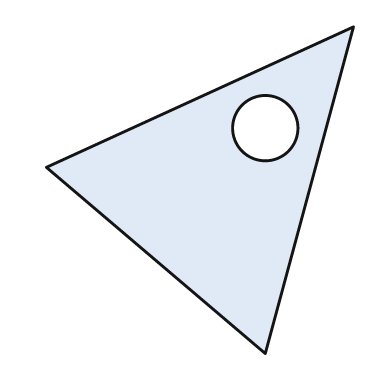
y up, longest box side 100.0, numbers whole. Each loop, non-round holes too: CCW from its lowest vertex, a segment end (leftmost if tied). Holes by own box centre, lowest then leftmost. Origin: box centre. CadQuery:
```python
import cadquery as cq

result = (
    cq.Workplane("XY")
    .moveTo(20.0, -50.0)
    .lineTo(47.0, 50.0)
    .lineTo(-47.0, 7.0)
    .close()
    .moveTo(20.0, 19.0)
    .circle(10.0)
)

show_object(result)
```